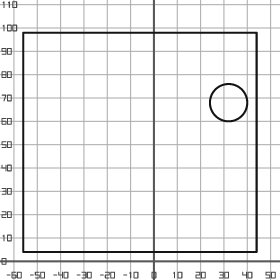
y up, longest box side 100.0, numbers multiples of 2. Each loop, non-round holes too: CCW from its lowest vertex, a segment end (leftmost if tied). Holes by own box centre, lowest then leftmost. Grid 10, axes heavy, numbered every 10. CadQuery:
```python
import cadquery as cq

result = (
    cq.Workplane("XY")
    .moveTo(-56.0, 4.0)
    .lineTo(44.0, 4.0)
    .lineTo(44.0, 98.0)
    .lineTo(-56.0, 98.0)
    .close()
    .moveTo(32.0, 68.0)
    .circle(8.0)
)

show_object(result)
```